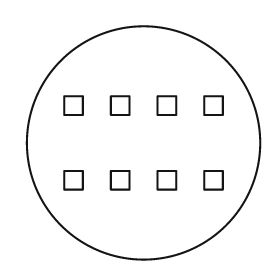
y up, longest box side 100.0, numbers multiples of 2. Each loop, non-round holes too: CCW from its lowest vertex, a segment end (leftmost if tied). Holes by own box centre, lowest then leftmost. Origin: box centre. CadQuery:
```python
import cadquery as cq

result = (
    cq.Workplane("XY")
    .moveTo(0.0, 0.0)
    .circle(50.0)
    .moveTo(-34.0, -20.0)
    .lineTo(-26.0, -20.0)
    .lineTo(-26.0, -12.0)
    .lineTo(-34.0, -12.0)
    .close()
    .moveTo(-14.0, -20.0)
    .lineTo(-6.0, -20.0)
    .lineTo(-6.0, -12.0)
    .lineTo(-14.0, -12.0)
    .close()
    .moveTo(6.0, -20.0)
    .lineTo(14.0, -20.0)
    .lineTo(14.0, -12.0)
    .lineTo(6.0, -12.0)
    .close()
    .moveTo(26.0, -20.0)
    .lineTo(34.0, -20.0)
    .lineTo(34.0, -12.0)
    .lineTo(26.0, -12.0)
    .close()
    .moveTo(-34.0, 12.0)
    .lineTo(-26.0, 12.0)
    .lineTo(-26.0, 20.0)
    .lineTo(-34.0, 20.0)
    .close()
    .moveTo(-14.0, 12.0)
    .lineTo(-6.0, 12.0)
    .lineTo(-6.0, 20.0)
    .lineTo(-14.0, 20.0)
    .close()
    .moveTo(6.0, 12.0)
    .lineTo(14.0, 12.0)
    .lineTo(14.0, 20.0)
    .lineTo(6.0, 20.0)
    .close()
    .moveTo(26.0, 12.0)
    .lineTo(34.0, 12.0)
    .lineTo(34.0, 20.0)
    .lineTo(26.0, 20.0)
    .close()
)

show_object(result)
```